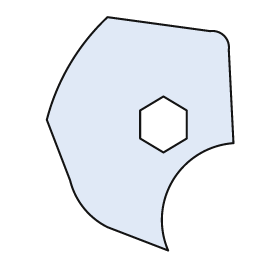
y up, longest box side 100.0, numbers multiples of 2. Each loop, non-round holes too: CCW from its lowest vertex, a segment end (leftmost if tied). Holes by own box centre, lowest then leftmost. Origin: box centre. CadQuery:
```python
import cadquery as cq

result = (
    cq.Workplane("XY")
    .moveTo(12.0, -50.0)
    .threePointArc((14.0, -20.0), (40.0, -4.0))
    .lineTo(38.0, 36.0)
    .threePointArc((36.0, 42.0), (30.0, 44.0))
    .lineTo(-14.0, 50.0)
    .threePointArc((-30.0, 30.0), (-40.0, 6.0))
    .lineTo(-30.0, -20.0)
    .threePointArc((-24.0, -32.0), (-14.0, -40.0))
    .close()
    .moveTo(10.0, -8.0)
    .lineTo(20.0, -2.0)
    .lineTo(20.0, 10.0)
    .lineTo(10.0, 16.0)
    .lineTo(0.0, 10.0)
    .lineTo(0.0, -2.0)
    .close()
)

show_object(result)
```